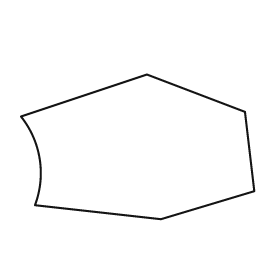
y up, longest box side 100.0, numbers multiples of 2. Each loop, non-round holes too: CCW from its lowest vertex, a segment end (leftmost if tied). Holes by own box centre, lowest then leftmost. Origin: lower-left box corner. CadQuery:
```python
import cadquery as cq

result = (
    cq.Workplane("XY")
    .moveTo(60.0, 0.0)
    .lineTo(100.0, 12.0)
    .lineTo(96.0, 46.0)
    .lineTo(54.0, 62.0)
    .lineTo(0.0, 44.0)
    .threePointArc((8.0, 26.0), (6.0, 6.0))
    .close()
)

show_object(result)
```